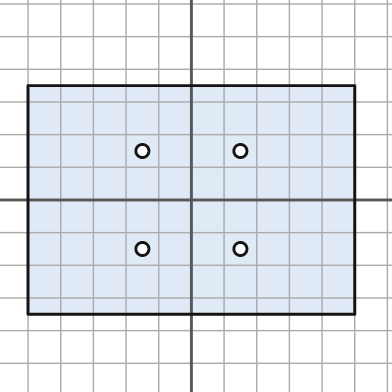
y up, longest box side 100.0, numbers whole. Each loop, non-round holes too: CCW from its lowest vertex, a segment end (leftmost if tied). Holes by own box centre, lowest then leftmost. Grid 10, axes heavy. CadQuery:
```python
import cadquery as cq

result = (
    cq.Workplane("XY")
    .moveTo(-50.0, -35.0)
    .lineTo(50.0, -35.0)
    .lineTo(50.0, 35.0)
    .lineTo(-50.0, 35.0)
    .close()
    .moveTo(-15.0, -15.0)
    .circle(2.0)
    .moveTo(15.0, -15.0)
    .circle(2.0)
    .moveTo(-15.0, 15.0)
    .circle(2.0)
    .moveTo(15.0, 15.0)
    .circle(2.0)
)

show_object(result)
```